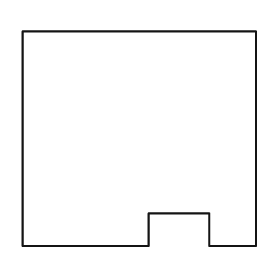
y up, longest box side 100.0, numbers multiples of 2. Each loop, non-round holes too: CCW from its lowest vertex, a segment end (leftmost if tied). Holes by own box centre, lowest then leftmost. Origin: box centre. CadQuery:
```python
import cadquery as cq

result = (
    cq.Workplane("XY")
    .moveTo(-50.0, -46.0)
    .lineTo(4.0, -46.0)
    .lineTo(4.0, -32.0)
    .lineTo(30.0, -32.0)
    .lineTo(30.0, -46.0)
    .lineTo(50.0, -46.0)
    .lineTo(50.0, 46.0)
    .lineTo(-50.0, 46.0)
    .close()
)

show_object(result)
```